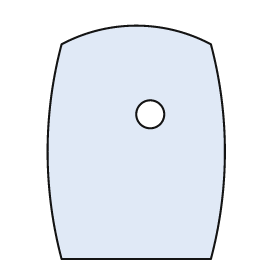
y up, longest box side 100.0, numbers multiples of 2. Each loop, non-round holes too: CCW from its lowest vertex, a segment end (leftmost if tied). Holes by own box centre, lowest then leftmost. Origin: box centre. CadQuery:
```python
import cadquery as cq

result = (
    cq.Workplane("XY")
    .moveTo(-32.0, -50.0)
    .lineTo(32.0, -50.0)
    .threePointArc((38.0, -4.0), (32.0, 42.0))
    .threePointArc((0.0, 50.0), (-32.0, 42.0))
    .threePointArc((-38.0, -4.0), (-32.0, -50.0))
    .close()
    .moveTo(6.0, 12.0)
    .circle(6.0)
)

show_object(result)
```